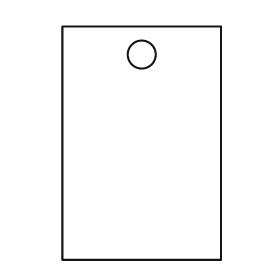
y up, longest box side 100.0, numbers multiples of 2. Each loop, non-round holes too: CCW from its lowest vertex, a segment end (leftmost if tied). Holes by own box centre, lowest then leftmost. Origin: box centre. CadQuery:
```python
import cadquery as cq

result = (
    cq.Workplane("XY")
    .moveTo(-34.0, -50.0)
    .lineTo(34.0, -50.0)
    .lineTo(34.0, 50.0)
    .lineTo(-34.0, 50.0)
    .close()
    .moveTo(0.0, 38.0)
    .circle(6.0)
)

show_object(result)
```